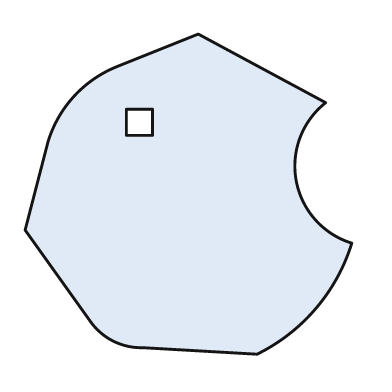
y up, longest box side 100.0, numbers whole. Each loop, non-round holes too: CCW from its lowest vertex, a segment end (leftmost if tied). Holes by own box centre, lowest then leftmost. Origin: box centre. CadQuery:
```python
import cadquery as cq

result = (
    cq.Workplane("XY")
    .moveTo(21.0, -49.0)
    .threePointArc((39.0, -35.0), (50.0, -15.0))
    .threePointArc((33.0, 4.0), (42.0, 28.0))
    .lineTo(3.0, 49.0)
    .lineTo(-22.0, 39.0)
    .threePointArc((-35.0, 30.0), (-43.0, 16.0))
    .lineTo(-50.0, -11.0)
    .lineTo(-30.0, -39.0)
    .threePointArc((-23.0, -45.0), (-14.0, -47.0))
    .close()
    .moveTo(-19.0, 18.0)
    .lineTo(-11.0, 18.0)
    .lineTo(-11.0, 26.0)
    .lineTo(-19.0, 26.0)
    .close()
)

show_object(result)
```